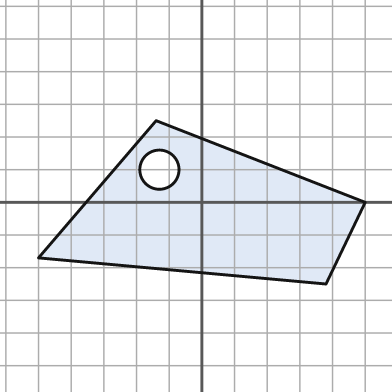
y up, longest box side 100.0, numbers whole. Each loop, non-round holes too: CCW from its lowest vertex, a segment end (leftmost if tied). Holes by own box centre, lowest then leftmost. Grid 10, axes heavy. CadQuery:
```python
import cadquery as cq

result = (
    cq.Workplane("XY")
    .moveTo(38.0, -25.0)
    .lineTo(50.0, 0.0)
    .lineTo(-14.0, 25.0)
    .lineTo(-50.0, -17.0)
    .close()
    .moveTo(-13.0, 10.0)
    .circle(6.0)
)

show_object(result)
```